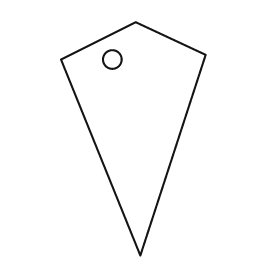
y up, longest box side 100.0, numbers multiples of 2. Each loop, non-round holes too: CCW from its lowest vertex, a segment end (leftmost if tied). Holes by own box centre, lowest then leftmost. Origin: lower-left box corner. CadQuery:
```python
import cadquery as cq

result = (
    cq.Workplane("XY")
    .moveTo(34.0, 0.0)
    .lineTo(62.0, 86.0)
    .lineTo(32.0, 100.0)
    .lineTo(0.0, 84.0)
    .close()
    .moveTo(22.0, 84.0)
    .circle(4.0)
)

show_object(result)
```